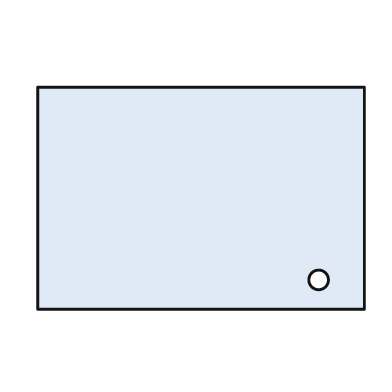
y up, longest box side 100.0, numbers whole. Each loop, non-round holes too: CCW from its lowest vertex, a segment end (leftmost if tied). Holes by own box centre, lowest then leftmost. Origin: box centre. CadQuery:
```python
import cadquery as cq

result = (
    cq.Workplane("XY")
    .moveTo(-50.0, -34.0)
    .lineTo(50.0, -34.0)
    .lineTo(50.0, 34.0)
    .lineTo(-50.0, 34.0)
    .close()
    .moveTo(36.0, -25.0)
    .circle(3.0)
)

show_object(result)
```